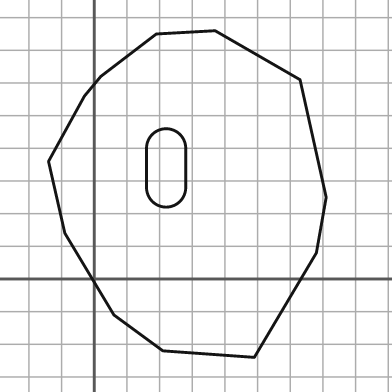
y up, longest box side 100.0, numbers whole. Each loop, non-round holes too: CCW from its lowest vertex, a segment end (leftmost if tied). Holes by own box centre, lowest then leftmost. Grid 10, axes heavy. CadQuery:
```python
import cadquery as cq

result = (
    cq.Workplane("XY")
    .moveTo(49.0, -24.0)
    .lineTo(68.0, 8.0)
    .lineTo(71.0, 25.0)
    .lineTo(63.0, 61.0)
    .lineTo(37.0, 76.0)
    .lineTo(19.0, 75.0)
    .lineTo(2.0, 62.0)
    .lineTo(-3.0, 56.0)
    .lineTo(-14.0, 36.0)
    .lineTo(-9.0, 14.0)
    .lineTo(6.0, -11.0)
    .lineTo(21.0, -22.0)
    .close()
    .moveTo(16.0, 28.0)
    .threePointArc((22.0, 22.0), (28.0, 28.0))
    .lineTo(28.0, 40.0)
    .threePointArc((22.0, 46.0), (16.0, 40.0))
    .close()
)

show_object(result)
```